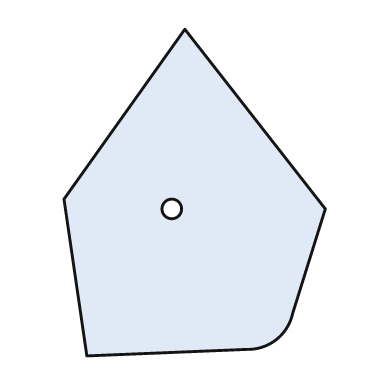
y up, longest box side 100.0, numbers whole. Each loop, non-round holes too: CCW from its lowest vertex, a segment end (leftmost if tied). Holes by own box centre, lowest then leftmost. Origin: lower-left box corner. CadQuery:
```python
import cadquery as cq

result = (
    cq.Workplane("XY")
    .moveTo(7.0, 0.0)
    .lineTo(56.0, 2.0)
    .threePointArc((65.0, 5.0), (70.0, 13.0))
    .lineTo(80.0, 45.0)
    .lineTo(37.0, 100.0)
    .lineTo(0.0, 48.0)
    .close()
    .moveTo(33.0, 45.0)
    .circle(3.0)
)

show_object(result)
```